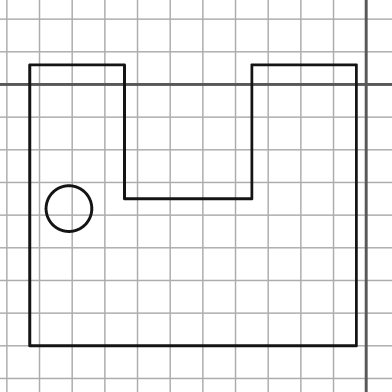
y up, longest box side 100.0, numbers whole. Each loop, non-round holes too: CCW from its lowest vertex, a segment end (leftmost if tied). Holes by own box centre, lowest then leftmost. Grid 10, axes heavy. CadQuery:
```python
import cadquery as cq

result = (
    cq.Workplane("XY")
    .moveTo(-103.0, -80.0)
    .lineTo(-3.0, -80.0)
    .lineTo(-3.0, 6.0)
    .lineTo(-35.0, 6.0)
    .lineTo(-35.0, -35.0)
    .lineTo(-74.0, -35.0)
    .lineTo(-74.0, 6.0)
    .lineTo(-103.0, 6.0)
    .close()
    .moveTo(-91.0, -38.0)
    .circle(7.0)
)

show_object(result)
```